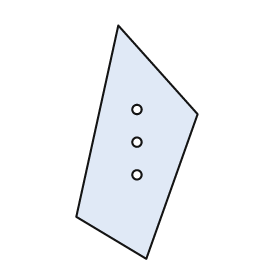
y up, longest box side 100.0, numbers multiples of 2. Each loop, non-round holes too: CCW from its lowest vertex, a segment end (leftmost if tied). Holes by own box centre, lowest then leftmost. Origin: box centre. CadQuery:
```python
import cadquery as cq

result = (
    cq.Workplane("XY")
    .moveTo(4.0, -50.0)
    .lineTo(26.0, 12.0)
    .lineTo(-8.0, 50.0)
    .lineTo(-26.0, -32.0)
    .close()
    .moveTo(0.0, -14.0)
    .circle(2.0)
    .moveTo(0.0, 0.0)
    .circle(2.0)
    .moveTo(0.0, 14.0)
    .circle(2.0)
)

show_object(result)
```